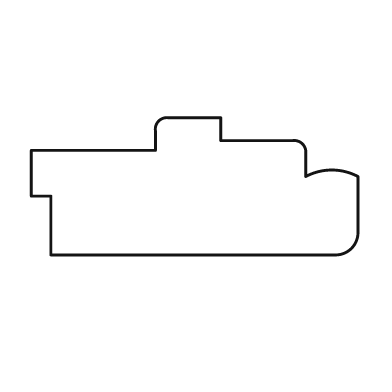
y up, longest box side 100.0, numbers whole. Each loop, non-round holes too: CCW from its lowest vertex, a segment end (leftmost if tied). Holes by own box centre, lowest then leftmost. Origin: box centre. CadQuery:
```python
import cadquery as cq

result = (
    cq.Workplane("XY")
    .moveTo(-44.0, -21.0)
    .lineTo(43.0, -21.0)
    .threePointArc((48.0, -19.0), (50.0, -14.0))
    .lineTo(50.0, 3.0)
    .threePointArc((42.0, 5.0), (34.0, 3.0))
    .lineTo(34.0, 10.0)
    .threePointArc((33.0, 13.0), (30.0, 14.0))
    .lineTo(8.0, 14.0)
    .lineTo(8.0, 21.0)
    .lineTo(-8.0, 21.0)
    .threePointArc((-11.0, 20.0), (-12.0, 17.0))
    .lineTo(-12.0, 11.0)
    .lineTo(-50.0, 11.0)
    .lineTo(-50.0, -3.0)
    .lineTo(-44.0, -3.0)
    .close()
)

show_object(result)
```